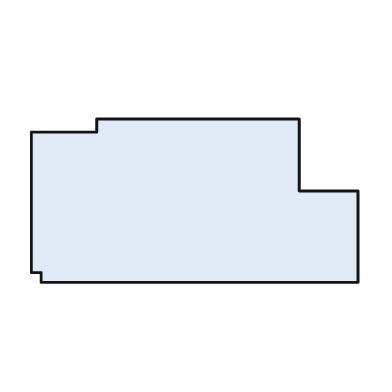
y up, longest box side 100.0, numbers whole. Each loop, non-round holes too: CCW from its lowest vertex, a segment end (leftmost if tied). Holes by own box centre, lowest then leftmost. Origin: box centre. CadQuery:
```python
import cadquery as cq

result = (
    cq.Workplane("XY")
    .moveTo(-47.0, -25.0)
    .lineTo(50.0, -25.0)
    .lineTo(50.0, 3.0)
    .lineTo(32.0, 3.0)
    .lineTo(32.0, 25.0)
    .lineTo(-30.0, 25.0)
    .lineTo(-30.0, 21.0)
    .lineTo(-50.0, 21.0)
    .lineTo(-50.0, -22.0)
    .lineTo(-47.0, -22.0)
    .close()
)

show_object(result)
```